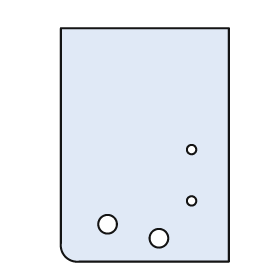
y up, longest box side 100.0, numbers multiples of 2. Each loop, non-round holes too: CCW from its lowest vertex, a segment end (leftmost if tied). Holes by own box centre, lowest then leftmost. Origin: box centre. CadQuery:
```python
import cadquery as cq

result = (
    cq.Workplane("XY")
    .moveTo(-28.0, -50.0)
    .lineTo(36.0, -50.0)
    .lineTo(36.0, 50.0)
    .lineTo(-36.0, 50.0)
    .lineTo(-36.0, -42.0)
    .threePointArc((-34.0, -48.0), (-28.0, -50.0))
    .close()
    .moveTo(6.0, -40.0)
    .circle(4.0)
    .moveTo(-16.0, -34.0)
    .circle(4.0)
    .moveTo(20.0, -24.0)
    .circle(2.0)
    .moveTo(20.0, -2.0)
    .circle(2.0)
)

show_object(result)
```